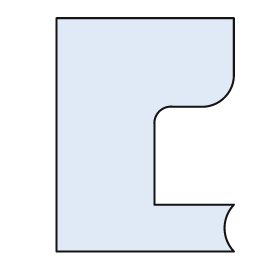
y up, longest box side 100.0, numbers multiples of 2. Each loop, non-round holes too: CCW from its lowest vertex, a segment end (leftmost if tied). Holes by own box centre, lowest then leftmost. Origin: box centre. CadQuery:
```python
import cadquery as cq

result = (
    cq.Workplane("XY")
    .moveTo(-38.0, -50.0)
    .lineTo(38.0, -50.0)
    .threePointArc((34.0, -40.0), (38.0, -30.0))
    .lineTo(4.0, -30.0)
    .lineTo(4.0, 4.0)
    .threePointArc((6.0, 10.0), (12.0, 12.0))
    .lineTo(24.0, 12.0)
    .threePointArc((34.0, 16.0), (38.0, 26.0))
    .lineTo(38.0, 50.0)
    .lineTo(-38.0, 50.0)
    .close()
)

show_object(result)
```